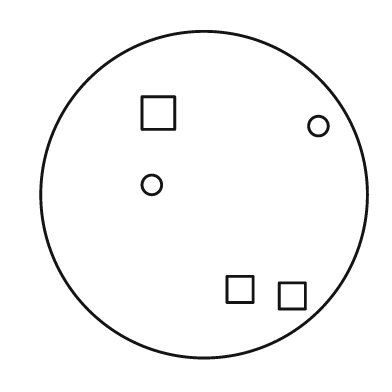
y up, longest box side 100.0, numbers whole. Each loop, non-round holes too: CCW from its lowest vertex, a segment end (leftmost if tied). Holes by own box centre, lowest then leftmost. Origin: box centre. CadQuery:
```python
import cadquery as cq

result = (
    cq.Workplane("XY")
    .moveTo(0.0, 0.0)
    .circle(50.0)
    .moveTo(23.0, -35.0)
    .lineTo(31.0, -35.0)
    .lineTo(31.0, -27.0)
    .lineTo(23.0, -27.0)
    .close()
    .moveTo(7.0, -33.0)
    .lineTo(15.0, -33.0)
    .lineTo(15.0, -25.0)
    .lineTo(7.0, -25.0)
    .close()
    .moveTo(-16.0, 3.0)
    .circle(3.0)
    .moveTo(35.0, 21.0)
    .circle(3.0)
    .moveTo(-19.0, 20.0)
    .lineTo(-9.0, 20.0)
    .lineTo(-9.0, 30.0)
    .lineTo(-19.0, 30.0)
    .close()
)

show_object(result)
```